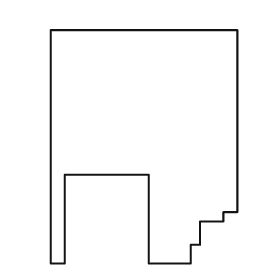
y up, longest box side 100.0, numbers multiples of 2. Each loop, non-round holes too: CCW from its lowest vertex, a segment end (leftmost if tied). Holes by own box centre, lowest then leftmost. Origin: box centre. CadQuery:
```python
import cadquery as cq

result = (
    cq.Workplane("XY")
    .moveTo(-40.0, -50.0)
    .lineTo(-34.0, -50.0)
    .lineTo(-34.0, -12.0)
    .lineTo(2.0, -12.0)
    .lineTo(2.0, -50.0)
    .lineTo(20.0, -50.0)
    .lineTo(20.0, -42.0)
    .lineTo(24.0, -42.0)
    .lineTo(24.0, -32.0)
    .lineTo(34.0, -32.0)
    .lineTo(34.0, -28.0)
    .lineTo(40.0, -28.0)
    .lineTo(40.0, 50.0)
    .lineTo(-40.0, 50.0)
    .close()
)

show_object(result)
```